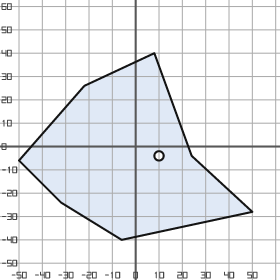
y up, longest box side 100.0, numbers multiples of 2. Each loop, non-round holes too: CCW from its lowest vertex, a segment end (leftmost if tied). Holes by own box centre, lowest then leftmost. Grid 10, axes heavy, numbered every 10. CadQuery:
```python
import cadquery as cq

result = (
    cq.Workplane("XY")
    .moveTo(-6.0, -40.0)
    .lineTo(50.0, -28.0)
    .lineTo(24.0, -4.0)
    .lineTo(8.0, 40.0)
    .lineTo(-22.0, 26.0)
    .lineTo(-50.0, -6.0)
    .lineTo(-32.0, -24.0)
    .close()
    .moveTo(10.0, -4.0)
    .circle(2.0)
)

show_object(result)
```